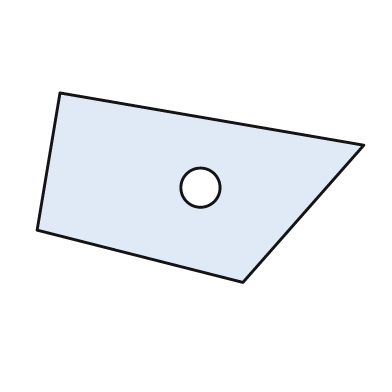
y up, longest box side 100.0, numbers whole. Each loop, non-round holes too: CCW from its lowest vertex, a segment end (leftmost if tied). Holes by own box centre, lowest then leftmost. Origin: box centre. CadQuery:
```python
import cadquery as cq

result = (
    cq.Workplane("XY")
    .moveTo(13.0, -29.0)
    .lineTo(50.0, 13.0)
    .lineTo(-43.0, 29.0)
    .lineTo(-50.0, -13.0)
    .close()
    .moveTo(0.0, 0.0)
    .circle(6.0)
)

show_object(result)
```